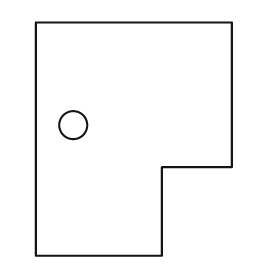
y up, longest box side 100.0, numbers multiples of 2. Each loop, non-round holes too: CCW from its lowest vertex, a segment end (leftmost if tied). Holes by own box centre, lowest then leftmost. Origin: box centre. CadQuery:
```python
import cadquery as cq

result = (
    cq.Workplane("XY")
    .moveTo(-42.0, -50.0)
    .lineTo(12.0, -50.0)
    .lineTo(12.0, -12.0)
    .lineTo(42.0, -12.0)
    .lineTo(42.0, 50.0)
    .lineTo(-42.0, 50.0)
    .close()
    .moveTo(-26.0, 6.0)
    .circle(6.0)
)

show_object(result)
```